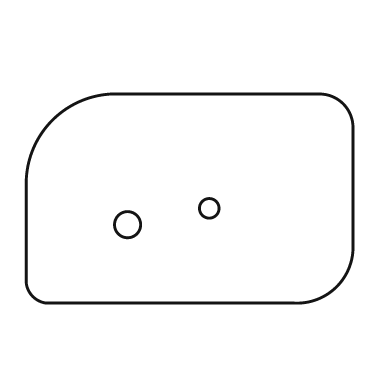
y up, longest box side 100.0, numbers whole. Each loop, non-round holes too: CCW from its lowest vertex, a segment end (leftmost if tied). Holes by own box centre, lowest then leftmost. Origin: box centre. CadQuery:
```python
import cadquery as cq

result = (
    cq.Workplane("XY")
    .moveTo(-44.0, -32.0)
    .lineTo(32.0, -32.0)
    .threePointArc((45.0, -27.0), (50.0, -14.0))
    .lineTo(50.0, 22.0)
    .threePointArc((47.0, 29.0), (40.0, 32.0))
    .lineTo(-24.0, 32.0)
    .threePointArc((-42.0, 24.0), (-50.0, 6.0))
    .lineTo(-50.0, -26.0)
    .threePointArc((-48.0, -30.0), (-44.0, -32.0))
    .close()
    .moveTo(-19.0, -8.0)
    .circle(4.0)
    .moveTo(6.0, -3.0)
    .circle(3.0)
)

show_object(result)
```